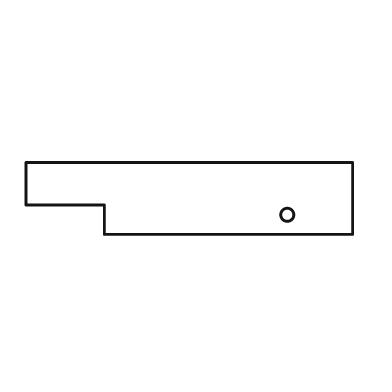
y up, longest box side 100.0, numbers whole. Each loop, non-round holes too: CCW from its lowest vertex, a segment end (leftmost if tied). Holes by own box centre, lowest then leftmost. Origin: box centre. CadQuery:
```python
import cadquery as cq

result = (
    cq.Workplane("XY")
    .moveTo(-26.0, -11.0)
    .lineTo(50.0, -11.0)
    .lineTo(50.0, 11.0)
    .lineTo(-50.0, 11.0)
    .lineTo(-50.0, -2.0)
    .lineTo(-26.0, -2.0)
    .close()
    .moveTo(30.0, -5.0)
    .circle(2.0)
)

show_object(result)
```